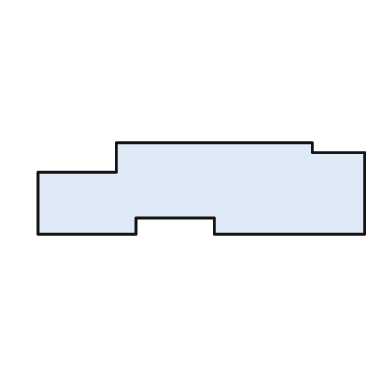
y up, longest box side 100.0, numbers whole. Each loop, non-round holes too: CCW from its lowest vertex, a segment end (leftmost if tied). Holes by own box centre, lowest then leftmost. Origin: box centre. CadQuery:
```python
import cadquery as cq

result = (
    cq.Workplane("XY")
    .moveTo(-50.0, -14.0)
    .lineTo(-20.0, -14.0)
    .lineTo(-20.0, -9.0)
    .lineTo(4.0, -9.0)
    .lineTo(4.0, -14.0)
    .lineTo(50.0, -14.0)
    .lineTo(50.0, 11.0)
    .lineTo(34.0, 11.0)
    .lineTo(34.0, 14.0)
    .lineTo(-26.0, 14.0)
    .lineTo(-26.0, 5.0)
    .lineTo(-50.0, 5.0)
    .close()
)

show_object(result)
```